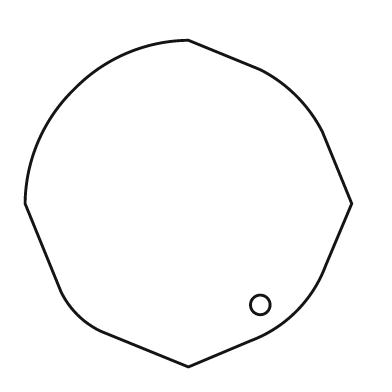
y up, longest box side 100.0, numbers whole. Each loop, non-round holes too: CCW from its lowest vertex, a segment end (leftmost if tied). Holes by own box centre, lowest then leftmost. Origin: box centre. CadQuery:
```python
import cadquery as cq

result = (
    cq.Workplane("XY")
    .moveTo(0.0, -50.0)
    .lineTo(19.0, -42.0)
    .threePointArc((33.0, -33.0), (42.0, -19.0))
    .lineTo(50.0, 0.0)
    .lineTo(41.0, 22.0)
    .threePointArc((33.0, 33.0), (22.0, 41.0))
    .lineTo(0.0, 50.0)
    .threePointArc((-19.0, 46.0), (-35.0, 35.0))
    .threePointArc((-46.0, 19.0), (-50.0, 0.0))
    .lineTo(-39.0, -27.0)
    .threePointArc((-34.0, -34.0), (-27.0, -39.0))
    .close()
    .moveTo(22.0, -31.0)
    .circle(3.0)
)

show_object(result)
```